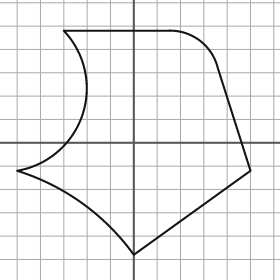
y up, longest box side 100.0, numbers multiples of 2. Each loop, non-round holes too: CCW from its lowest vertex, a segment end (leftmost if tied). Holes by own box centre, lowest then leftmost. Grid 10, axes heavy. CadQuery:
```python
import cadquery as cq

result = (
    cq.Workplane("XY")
    .moveTo(0.0, -48.0)
    .lineTo(50.0, -12.0)
    .lineTo(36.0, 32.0)
    .threePointArc((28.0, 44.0), (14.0, 48.0))
    .lineTo(-30.0, 48.0)
    .threePointArc((-22.0, 12.0), (-50.0, -12.0))
    .threePointArc((-22.0, -26.0), (0.0, -48.0))
    .close()
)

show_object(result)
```